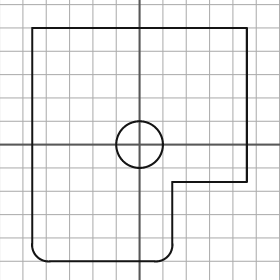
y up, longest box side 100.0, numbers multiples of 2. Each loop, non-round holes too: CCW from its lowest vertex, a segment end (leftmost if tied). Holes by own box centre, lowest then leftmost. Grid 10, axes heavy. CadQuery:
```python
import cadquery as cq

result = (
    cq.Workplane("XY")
    .moveTo(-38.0, -50.0)
    .lineTo(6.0, -50.0)
    .threePointArc((12.0, -48.0), (14.0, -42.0))
    .lineTo(14.0, -16.0)
    .lineTo(46.0, -16.0)
    .lineTo(46.0, 50.0)
    .lineTo(-46.0, 50.0)
    .lineTo(-46.0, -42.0)
    .threePointArc((-44.0, -48.0), (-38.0, -50.0))
    .close()
    .moveTo(0.0, 0.0)
    .circle(10.0)
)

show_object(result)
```